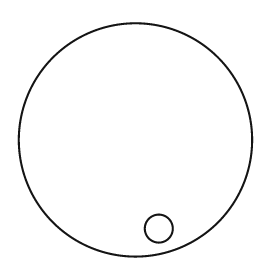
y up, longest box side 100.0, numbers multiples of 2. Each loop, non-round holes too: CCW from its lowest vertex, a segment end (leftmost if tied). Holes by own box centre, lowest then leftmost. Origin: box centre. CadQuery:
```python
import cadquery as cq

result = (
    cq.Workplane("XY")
    .moveTo(0.0, 0.0)
    .circle(50.0)
    .moveTo(10.0, -38.0)
    .circle(6.0)
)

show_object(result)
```